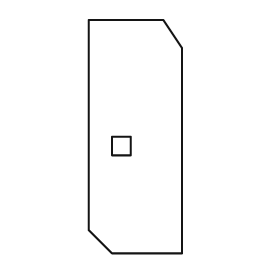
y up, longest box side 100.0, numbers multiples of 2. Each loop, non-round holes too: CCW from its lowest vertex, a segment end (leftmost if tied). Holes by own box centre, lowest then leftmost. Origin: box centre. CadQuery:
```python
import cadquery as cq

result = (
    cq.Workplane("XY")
    .moveTo(-10.0, -50.0)
    .lineTo(20.0, -50.0)
    .lineTo(20.0, 38.0)
    .lineTo(12.0, 50.0)
    .lineTo(-20.0, 50.0)
    .lineTo(-20.0, -40.0)
    .close()
    .moveTo(-10.0, -8.0)
    .lineTo(-2.0, -8.0)
    .lineTo(-2.0, 0.0)
    .lineTo(-10.0, 0.0)
    .close()
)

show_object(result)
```